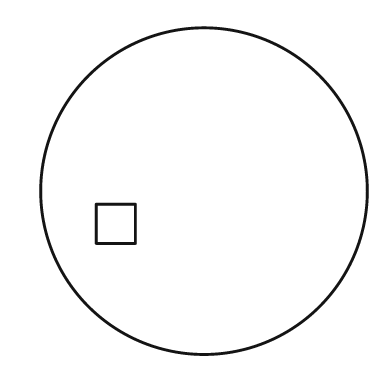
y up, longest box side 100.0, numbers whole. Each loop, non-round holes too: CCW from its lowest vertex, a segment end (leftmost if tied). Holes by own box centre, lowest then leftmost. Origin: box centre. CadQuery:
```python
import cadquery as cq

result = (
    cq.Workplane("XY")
    .moveTo(0.0, 0.0)
    .circle(50.0)
    .moveTo(-33.0, -16.0)
    .lineTo(-21.0, -16.0)
    .lineTo(-21.0, -4.0)
    .lineTo(-33.0, -4.0)
    .close()
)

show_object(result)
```